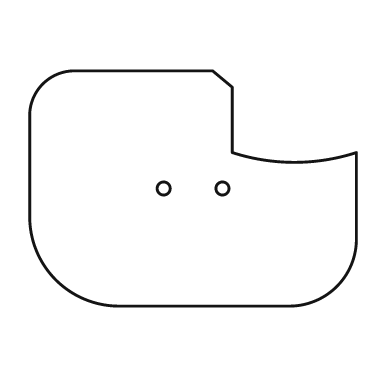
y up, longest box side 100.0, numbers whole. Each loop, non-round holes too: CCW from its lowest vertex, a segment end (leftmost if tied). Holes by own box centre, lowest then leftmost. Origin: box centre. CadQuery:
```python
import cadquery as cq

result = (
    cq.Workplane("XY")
    .moveTo(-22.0, -36.0)
    .lineTo(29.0, -36.0)
    .threePointArc((44.0, -30.0), (50.0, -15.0))
    .lineTo(50.0, 11.0)
    .threePointArc((31.0, 8.0), (12.0, 11.0))
    .lineTo(12.0, 31.0)
    .lineTo(6.0, 36.0)
    .lineTo(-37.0, 36.0)
    .threePointArc((-46.0, 32.0), (-50.0, 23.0))
    .lineTo(-50.0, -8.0)
    .threePointArc((-42.0, -28.0), (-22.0, -36.0))
    .close()
    .moveTo(-9.0, 0.0)
    .circle(2.0)
    .moveTo(9.0, 0.0)
    .circle(2.0)
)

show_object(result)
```